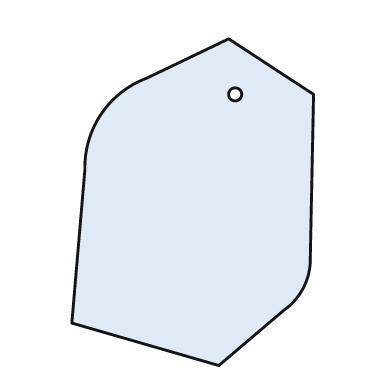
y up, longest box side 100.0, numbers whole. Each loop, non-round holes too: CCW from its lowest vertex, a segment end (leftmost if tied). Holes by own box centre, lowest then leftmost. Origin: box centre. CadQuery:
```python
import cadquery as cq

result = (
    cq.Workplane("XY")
    .moveTo(8.0, -50.0)
    .lineTo(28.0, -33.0)
    .threePointArc((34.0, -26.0), (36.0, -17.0))
    .lineTo(37.0, 33.0)
    .lineTo(11.0, 50.0)
    .lineTo(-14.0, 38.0)
    .threePointArc((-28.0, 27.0), (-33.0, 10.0))
    .lineTo(-37.0, -37.0)
    .close()
    .moveTo(13.0, 33.0)
    .circle(2.0)
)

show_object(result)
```